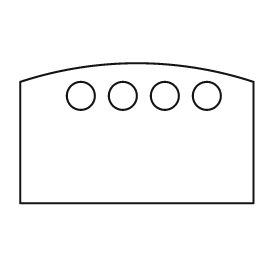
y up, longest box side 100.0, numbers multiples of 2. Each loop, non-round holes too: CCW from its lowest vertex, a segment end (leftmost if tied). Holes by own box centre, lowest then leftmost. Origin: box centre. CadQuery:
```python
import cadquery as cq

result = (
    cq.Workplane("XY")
    .moveTo(-50.0, -30.0)
    .lineTo(50.0, -30.0)
    .lineTo(50.0, 22.0)
    .threePointArc((0.0, 30.0), (-50.0, 22.0))
    .close()
    .moveTo(-24.0, 16.0)
    .circle(6.0)
    .moveTo(-6.0, 16.0)
    .circle(6.0)
    .moveTo(12.0, 16.0)
    .circle(6.0)
    .moveTo(30.0, 16.0)
    .circle(6.0)
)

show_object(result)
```